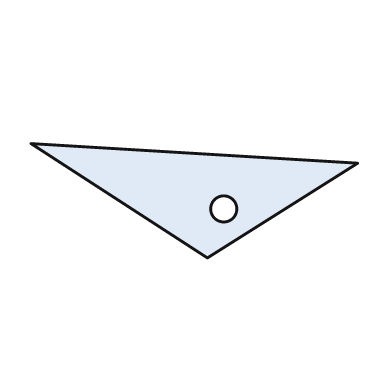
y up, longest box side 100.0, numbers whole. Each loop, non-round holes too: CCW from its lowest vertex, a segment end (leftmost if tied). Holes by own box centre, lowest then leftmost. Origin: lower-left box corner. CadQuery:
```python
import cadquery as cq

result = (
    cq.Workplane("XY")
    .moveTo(54.0, 0.0)
    .lineTo(100.0, 29.0)
    .lineTo(0.0, 35.0)
    .close()
    .moveTo(59.0, 15.0)
    .circle(4.0)
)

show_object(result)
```